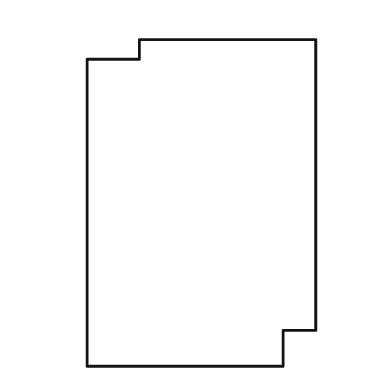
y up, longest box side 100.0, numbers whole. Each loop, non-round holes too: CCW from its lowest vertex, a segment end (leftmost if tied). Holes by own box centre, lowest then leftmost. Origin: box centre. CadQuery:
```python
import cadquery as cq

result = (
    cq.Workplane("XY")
    .moveTo(-35.0, -50.0)
    .lineTo(25.0, -50.0)
    .lineTo(25.0, -39.0)
    .lineTo(35.0, -39.0)
    .lineTo(35.0, 50.0)
    .lineTo(-19.0, 50.0)
    .lineTo(-19.0, 44.0)
    .lineTo(-35.0, 44.0)
    .close()
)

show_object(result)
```